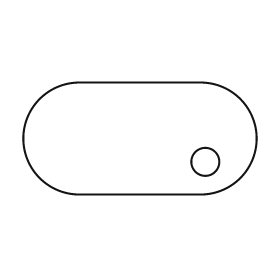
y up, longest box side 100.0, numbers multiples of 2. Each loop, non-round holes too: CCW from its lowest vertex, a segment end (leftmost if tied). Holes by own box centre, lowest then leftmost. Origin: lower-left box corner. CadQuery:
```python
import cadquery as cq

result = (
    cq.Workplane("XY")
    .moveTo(24.0, 0.0)
    .lineTo(76.0, 0.0)
    .threePointArc((100.0, 24.0), (76.0, 48.0))
    .lineTo(24.0, 48.0)
    .threePointArc((0.0, 24.0), (24.0, 0.0))
    .close()
    .moveTo(78.0, 14.0)
    .circle(6.0)
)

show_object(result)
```